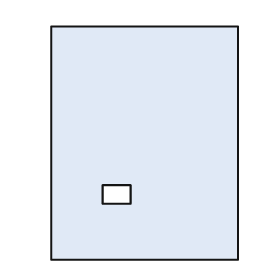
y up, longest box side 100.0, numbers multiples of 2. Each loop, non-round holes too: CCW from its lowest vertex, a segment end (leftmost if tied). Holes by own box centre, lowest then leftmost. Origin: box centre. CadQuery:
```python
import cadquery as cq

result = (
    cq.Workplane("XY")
    .moveTo(-40.0, -50.0)
    .lineTo(40.0, -50.0)
    .lineTo(40.0, 50.0)
    .lineTo(-40.0, 50.0)
    .close()
    .moveTo(-18.0, -26.0)
    .lineTo(-6.0, -26.0)
    .lineTo(-6.0, -18.0)
    .lineTo(-18.0, -18.0)
    .close()
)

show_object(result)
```